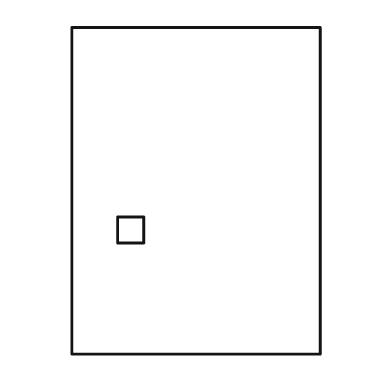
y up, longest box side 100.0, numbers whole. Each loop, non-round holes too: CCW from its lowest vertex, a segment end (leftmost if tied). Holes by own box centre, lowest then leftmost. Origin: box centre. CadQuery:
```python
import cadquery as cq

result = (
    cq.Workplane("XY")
    .moveTo(-38.0, -50.0)
    .lineTo(38.0, -50.0)
    .lineTo(38.0, 50.0)
    .lineTo(-38.0, 50.0)
    .close()
    .moveTo(-24.0, -16.0)
    .lineTo(-16.0, -16.0)
    .lineTo(-16.0, -8.0)
    .lineTo(-24.0, -8.0)
    .close()
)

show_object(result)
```